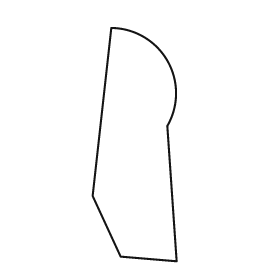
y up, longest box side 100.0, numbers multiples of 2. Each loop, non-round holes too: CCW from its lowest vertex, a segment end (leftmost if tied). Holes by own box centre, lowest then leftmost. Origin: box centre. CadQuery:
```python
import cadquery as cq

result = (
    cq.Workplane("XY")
    .moveTo(18.0, -50.0)
    .lineTo(14.0, 8.0)
    .threePointArc((14.0, 36.0), (-10.0, 50.0))
    .lineTo(-18.0, -22.0)
    .lineTo(-6.0, -48.0)
    .close()
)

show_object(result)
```